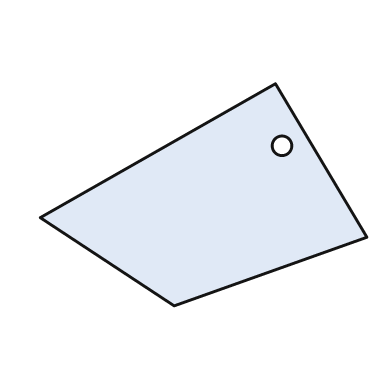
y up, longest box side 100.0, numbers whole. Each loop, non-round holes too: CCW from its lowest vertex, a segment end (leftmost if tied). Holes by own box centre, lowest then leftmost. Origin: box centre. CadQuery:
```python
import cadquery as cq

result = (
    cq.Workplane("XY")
    .moveTo(-9.0, -34.0)
    .lineTo(50.0, -13.0)
    .lineTo(22.0, 34.0)
    .lineTo(-50.0, -7.0)
    .close()
    .moveTo(24.0, 15.0)
    .circle(3.0)
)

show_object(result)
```